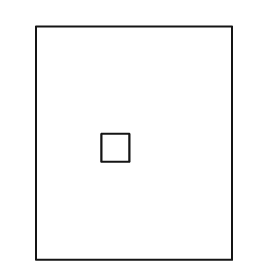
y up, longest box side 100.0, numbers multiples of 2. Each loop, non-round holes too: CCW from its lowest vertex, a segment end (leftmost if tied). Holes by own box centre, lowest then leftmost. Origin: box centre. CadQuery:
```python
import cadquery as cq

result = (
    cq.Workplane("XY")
    .moveTo(-42.0, -50.0)
    .lineTo(42.0, -50.0)
    .lineTo(42.0, 50.0)
    .lineTo(-42.0, 50.0)
    .close()
    .moveTo(-14.0, -8.0)
    .lineTo(-2.0, -8.0)
    .lineTo(-2.0, 4.0)
    .lineTo(-14.0, 4.0)
    .close()
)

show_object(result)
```